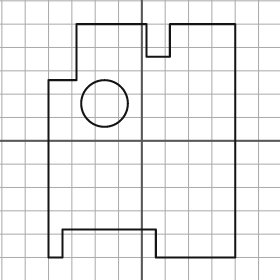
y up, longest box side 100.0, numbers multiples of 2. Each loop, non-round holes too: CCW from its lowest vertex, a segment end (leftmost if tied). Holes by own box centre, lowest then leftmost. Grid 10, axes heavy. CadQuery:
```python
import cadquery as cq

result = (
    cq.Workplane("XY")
    .moveTo(-40.0, -50.0)
    .lineTo(-34.0, -50.0)
    .lineTo(-34.0, -38.0)
    .lineTo(6.0, -38.0)
    .lineTo(6.0, -50.0)
    .lineTo(40.0, -50.0)
    .lineTo(40.0, 50.0)
    .lineTo(12.0, 50.0)
    .lineTo(12.0, 36.0)
    .lineTo(2.0, 36.0)
    .lineTo(2.0, 50.0)
    .lineTo(-28.0, 50.0)
    .lineTo(-28.0, 26.0)
    .lineTo(-40.0, 26.0)
    .close()
    .moveTo(-16.0, 16.0)
    .circle(10.0)
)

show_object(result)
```